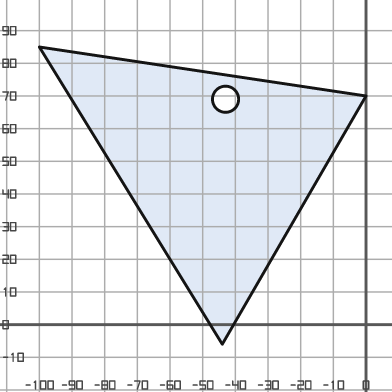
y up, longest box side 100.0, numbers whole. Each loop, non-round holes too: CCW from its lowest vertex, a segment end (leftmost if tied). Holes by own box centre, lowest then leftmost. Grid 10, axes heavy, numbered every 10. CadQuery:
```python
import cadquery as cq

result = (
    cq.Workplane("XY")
    .moveTo(-44.0, -6.0)
    .lineTo(0.0, 70.0)
    .lineTo(-100.0, 85.0)
    .close()
    .moveTo(-43.0, 69.0)
    .circle(4.0)
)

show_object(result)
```